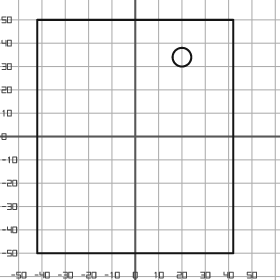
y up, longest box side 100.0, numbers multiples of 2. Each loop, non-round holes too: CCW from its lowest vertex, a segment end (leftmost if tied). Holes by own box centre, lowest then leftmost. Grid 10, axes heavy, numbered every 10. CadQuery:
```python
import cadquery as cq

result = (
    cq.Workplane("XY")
    .moveTo(-42.0, -50.0)
    .lineTo(42.0, -50.0)
    .lineTo(42.0, 50.0)
    .lineTo(-42.0, 50.0)
    .close()
    .moveTo(20.0, 34.0)
    .circle(4.0)
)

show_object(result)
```